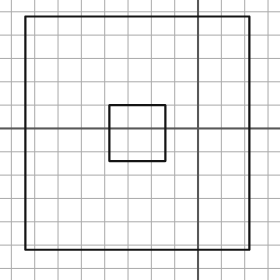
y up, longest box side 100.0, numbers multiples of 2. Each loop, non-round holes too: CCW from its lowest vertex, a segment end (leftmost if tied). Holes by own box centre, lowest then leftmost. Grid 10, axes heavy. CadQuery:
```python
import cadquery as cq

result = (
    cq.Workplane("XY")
    .moveTo(-74.0, -52.0)
    .lineTo(22.0, -52.0)
    .lineTo(22.0, 48.0)
    .lineTo(-74.0, 48.0)
    .close()
    .moveTo(-38.0, -14.0)
    .lineTo(-14.0, -14.0)
    .lineTo(-14.0, 10.0)
    .lineTo(-38.0, 10.0)
    .close()
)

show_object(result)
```